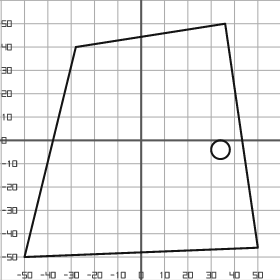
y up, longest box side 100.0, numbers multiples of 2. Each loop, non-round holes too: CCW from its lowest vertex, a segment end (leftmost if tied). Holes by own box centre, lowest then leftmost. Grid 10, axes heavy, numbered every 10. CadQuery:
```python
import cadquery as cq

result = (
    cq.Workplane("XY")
    .moveTo(-50.0, -50.0)
    .lineTo(50.0, -46.0)
    .lineTo(36.0, 50.0)
    .lineTo(-28.0, 40.0)
    .close()
    .moveTo(34.0, -4.0)
    .circle(4.0)
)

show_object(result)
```